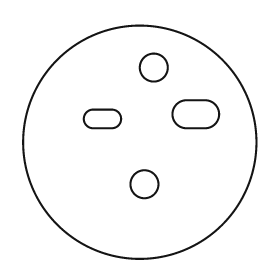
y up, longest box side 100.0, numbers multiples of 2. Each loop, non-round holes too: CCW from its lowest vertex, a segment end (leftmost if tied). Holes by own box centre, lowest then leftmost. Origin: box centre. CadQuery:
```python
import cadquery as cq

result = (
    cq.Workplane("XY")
    .moveTo(0.0, 0.0)
    .circle(50.0)
    .moveTo(2.0, -18.0)
    .circle(6.0)
    .moveTo(-20.0, 6.0)
    .lineTo(-12.0, 6.0)
    .threePointArc((-8.0, 10.0), (-12.0, 14.0))
    .lineTo(-20.0, 14.0)
    .threePointArc((-24.0, 10.0), (-20.0, 6.0))
    .close()
    .moveTo(20.0, 6.0)
    .lineTo(28.0, 6.0)
    .threePointArc((34.0, 12.0), (28.0, 18.0))
    .lineTo(20.0, 18.0)
    .threePointArc((14.0, 12.0), (20.0, 6.0))
    .close()
    .moveTo(6.0, 32.0)
    .circle(6.0)
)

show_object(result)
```